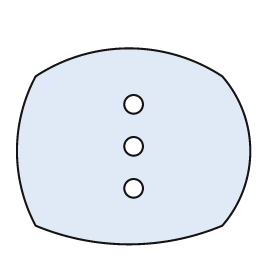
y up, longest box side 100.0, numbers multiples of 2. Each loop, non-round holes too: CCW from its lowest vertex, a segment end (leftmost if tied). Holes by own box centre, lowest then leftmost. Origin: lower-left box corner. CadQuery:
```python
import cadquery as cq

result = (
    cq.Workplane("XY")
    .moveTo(8.0, 8.0)
    .threePointArc((48.0, 0.0), (88.0, 8.0))
    .threePointArc((100.0, 40.0), (88.0, 72.0))
    .threePointArc((48.0, 84.0), (8.0, 72.0))
    .threePointArc((0.0, 40.0), (8.0, 8.0))
    .close()
    .moveTo(50.0, 24.0)
    .circle(4.0)
    .moveTo(50.0, 42.0)
    .circle(4.0)
    .moveTo(50.0, 60.0)
    .circle(4.0)
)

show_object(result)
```